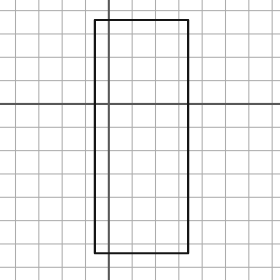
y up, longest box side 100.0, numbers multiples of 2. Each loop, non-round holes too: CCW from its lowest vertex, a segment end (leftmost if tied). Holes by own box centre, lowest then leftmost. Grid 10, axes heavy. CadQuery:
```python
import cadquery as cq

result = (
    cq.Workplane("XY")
    .moveTo(-6.0, -64.0)
    .lineTo(34.0, -64.0)
    .lineTo(34.0, 36.0)
    .lineTo(-6.0, 36.0)
    .close()
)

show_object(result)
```